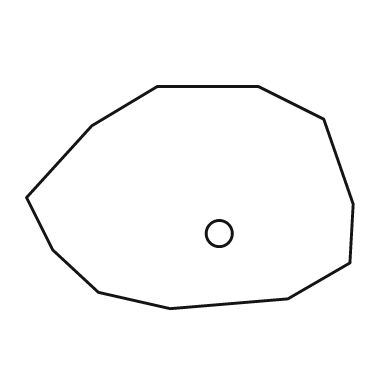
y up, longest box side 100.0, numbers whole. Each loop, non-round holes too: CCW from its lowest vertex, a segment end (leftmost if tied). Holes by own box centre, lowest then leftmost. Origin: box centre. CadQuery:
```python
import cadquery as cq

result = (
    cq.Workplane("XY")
    .moveTo(-6.0, -34.0)
    .lineTo(30.0, -31.0)
    .lineTo(49.0, -20.0)
    .lineTo(50.0, -2.0)
    .lineTo(41.0, 24.0)
    .lineTo(21.0, 34.0)
    .lineTo(-10.0, 34.0)
    .lineTo(-30.0, 22.0)
    .lineTo(-50.0, 0.0)
    .lineTo(-42.0, -16.0)
    .lineTo(-28.0, -29.0)
    .close()
    .moveTo(9.0, -11.0)
    .circle(4.0)
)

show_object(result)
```